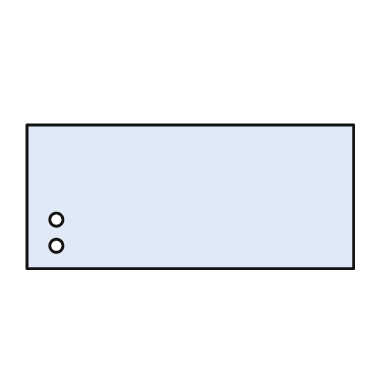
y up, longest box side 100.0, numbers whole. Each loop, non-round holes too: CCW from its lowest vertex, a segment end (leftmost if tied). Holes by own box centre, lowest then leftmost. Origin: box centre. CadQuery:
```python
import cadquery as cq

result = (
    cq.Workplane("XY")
    .moveTo(-50.0, -22.0)
    .lineTo(50.0, -22.0)
    .lineTo(50.0, 22.0)
    .lineTo(-50.0, 22.0)
    .close()
    .moveTo(-41.0, -15.0)
    .circle(2.0)
    .moveTo(-41.0, -7.0)
    .circle(2.0)
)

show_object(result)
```